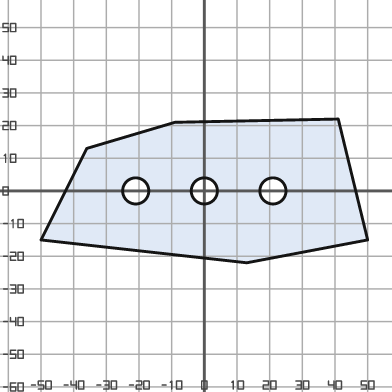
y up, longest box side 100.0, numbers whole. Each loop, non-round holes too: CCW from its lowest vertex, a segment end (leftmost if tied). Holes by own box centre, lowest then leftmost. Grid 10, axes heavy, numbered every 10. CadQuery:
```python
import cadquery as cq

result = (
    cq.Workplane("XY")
    .moveTo(13.0, -22.0)
    .lineTo(50.0, -15.0)
    .lineTo(41.0, 22.0)
    .lineTo(-9.0, 21.0)
    .lineTo(-36.0, 13.0)
    .lineTo(-50.0, -15.0)
    .close()
    .moveTo(-21.0, 0.0)
    .circle(4.0)
    .moveTo(0.0, 0.0)
    .circle(4.0)
    .moveTo(21.0, 0.0)
    .circle(4.0)
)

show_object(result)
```